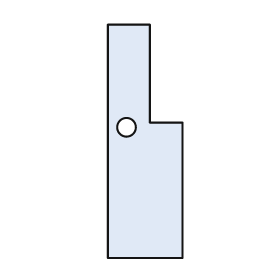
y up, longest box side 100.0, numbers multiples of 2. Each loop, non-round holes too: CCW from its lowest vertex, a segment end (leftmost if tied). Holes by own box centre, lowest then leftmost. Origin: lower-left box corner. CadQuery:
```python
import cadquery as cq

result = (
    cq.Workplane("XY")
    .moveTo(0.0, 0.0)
    .lineTo(32.0, 0.0)
    .lineTo(32.0, 58.0)
    .lineTo(18.0, 58.0)
    .lineTo(18.0, 100.0)
    .lineTo(0.0, 100.0)
    .close()
    .moveTo(8.0, 56.0)
    .circle(4.0)
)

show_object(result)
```